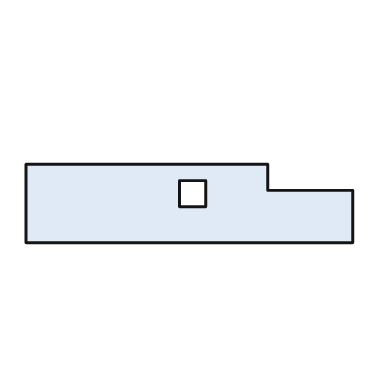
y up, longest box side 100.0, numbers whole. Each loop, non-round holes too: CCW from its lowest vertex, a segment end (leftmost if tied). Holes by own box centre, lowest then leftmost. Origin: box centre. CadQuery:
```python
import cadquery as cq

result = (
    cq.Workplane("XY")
    .moveTo(-50.0, -12.0)
    .lineTo(50.0, -12.0)
    .lineTo(50.0, 4.0)
    .lineTo(24.0, 4.0)
    .lineTo(24.0, 12.0)
    .lineTo(-50.0, 12.0)
    .close()
    .moveTo(-3.0, -1.0)
    .lineTo(5.0, -1.0)
    .lineTo(5.0, 7.0)
    .lineTo(-3.0, 7.0)
    .close()
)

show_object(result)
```